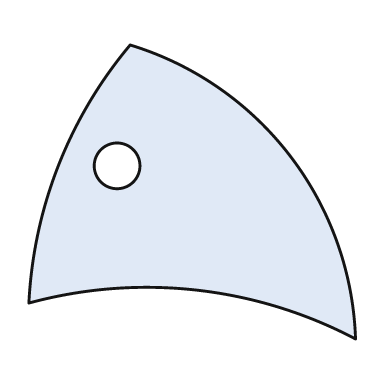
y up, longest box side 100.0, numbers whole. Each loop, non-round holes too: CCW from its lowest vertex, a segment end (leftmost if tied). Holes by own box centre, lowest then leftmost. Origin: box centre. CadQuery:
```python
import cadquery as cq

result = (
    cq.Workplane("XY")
    .moveTo(50.0, -45.0)
    .threePointArc((30.0, 11.0), (-19.0, 45.0))
    .threePointArc((-41.0, 8.0), (-50.0, -34.0))
    .threePointArc((1.0, -30.0), (50.0, -45.0))
    .close()
    .moveTo(-23.0, 8.0)
    .circle(7.0)
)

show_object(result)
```